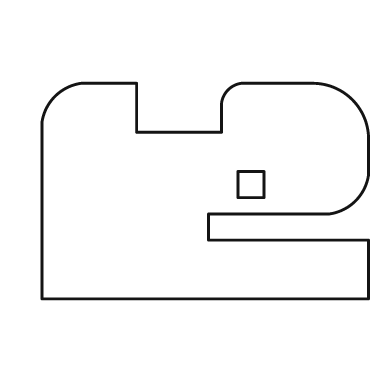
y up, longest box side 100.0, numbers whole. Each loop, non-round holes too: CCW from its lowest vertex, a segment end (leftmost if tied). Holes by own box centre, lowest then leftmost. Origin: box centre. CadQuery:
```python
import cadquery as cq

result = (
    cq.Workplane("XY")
    .moveTo(-50.0, -33.0)
    .lineTo(50.0, -33.0)
    .lineTo(50.0, -15.0)
    .lineTo(1.0, -15.0)
    .lineTo(1.0, -7.0)
    .lineTo(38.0, -7.0)
    .threePointArc((46.0, -3.0), (50.0, 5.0))
    .lineTo(50.0, 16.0)
    .threePointArc((45.0, 28.0), (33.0, 33.0))
    .lineTo(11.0, 33.0)
    .threePointArc((7.0, 31.0), (5.0, 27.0))
    .lineTo(5.0, 18.0)
    .lineTo(-21.0, 18.0)
    .lineTo(-21.0, 33.0)
    .lineTo(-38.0, 33.0)
    .threePointArc((-46.0, 29.0), (-50.0, 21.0))
    .close()
    .moveTo(10.0, -2.0)
    .lineTo(18.0, -2.0)
    .lineTo(18.0, 6.0)
    .lineTo(10.0, 6.0)
    .close()
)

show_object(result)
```